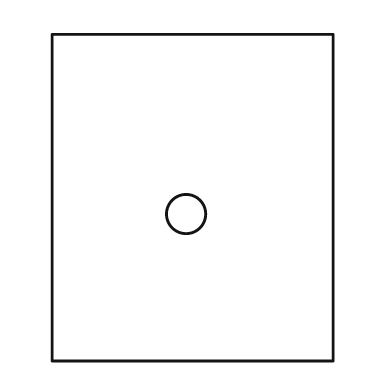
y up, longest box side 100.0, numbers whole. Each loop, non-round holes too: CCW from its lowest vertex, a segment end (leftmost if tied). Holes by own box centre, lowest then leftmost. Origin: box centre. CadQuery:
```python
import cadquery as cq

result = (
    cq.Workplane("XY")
    .moveTo(-43.0, -50.0)
    .lineTo(43.0, -50.0)
    .lineTo(43.0, 50.0)
    .lineTo(-43.0, 50.0)
    .close()
    .moveTo(-2.0, -5.0)
    .circle(6.0)
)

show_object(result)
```